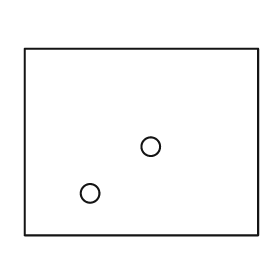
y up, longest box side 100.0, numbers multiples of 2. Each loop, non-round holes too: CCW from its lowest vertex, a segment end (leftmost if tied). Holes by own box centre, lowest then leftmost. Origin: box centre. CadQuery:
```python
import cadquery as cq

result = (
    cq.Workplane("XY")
    .moveTo(-50.0, -40.0)
    .lineTo(50.0, -40.0)
    .lineTo(50.0, 40.0)
    .lineTo(-50.0, 40.0)
    .close()
    .moveTo(-22.0, -22.0)
    .circle(4.0)
    .moveTo(4.0, -2.0)
    .circle(4.0)
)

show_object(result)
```